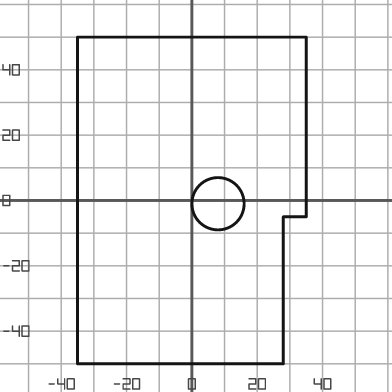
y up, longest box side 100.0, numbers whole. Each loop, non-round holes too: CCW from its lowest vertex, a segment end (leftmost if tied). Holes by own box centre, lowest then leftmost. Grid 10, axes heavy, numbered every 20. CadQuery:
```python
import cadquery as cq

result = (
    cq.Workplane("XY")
    .moveTo(-35.0, -50.0)
    .lineTo(28.0, -50.0)
    .lineTo(28.0, -5.0)
    .lineTo(35.0, -5.0)
    .lineTo(35.0, 50.0)
    .lineTo(-35.0, 50.0)
    .close()
    .moveTo(8.0, -1.0)
    .circle(8.0)
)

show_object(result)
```